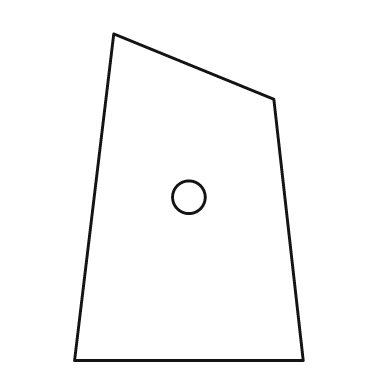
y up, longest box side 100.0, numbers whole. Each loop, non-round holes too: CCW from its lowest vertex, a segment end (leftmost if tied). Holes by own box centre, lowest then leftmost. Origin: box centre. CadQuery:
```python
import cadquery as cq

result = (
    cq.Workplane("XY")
    .moveTo(-35.0, -50.0)
    .lineTo(35.0, -50.0)
    .lineTo(26.0, 30.0)
    .lineTo(-23.0, 50.0)
    .close()
    .moveTo(0.0, 0.0)
    .circle(5.0)
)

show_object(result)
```